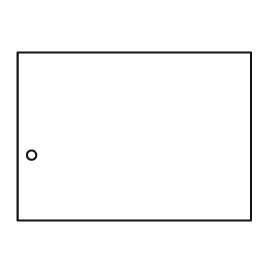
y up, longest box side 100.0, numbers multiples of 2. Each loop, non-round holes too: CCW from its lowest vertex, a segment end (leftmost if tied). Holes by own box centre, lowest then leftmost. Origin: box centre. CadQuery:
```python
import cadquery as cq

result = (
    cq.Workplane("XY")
    .moveTo(-50.0, -36.0)
    .lineTo(50.0, -36.0)
    .lineTo(50.0, 36.0)
    .lineTo(-50.0, 36.0)
    .close()
    .moveTo(-44.0, -8.0)
    .circle(2.0)
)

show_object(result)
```